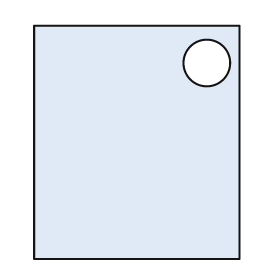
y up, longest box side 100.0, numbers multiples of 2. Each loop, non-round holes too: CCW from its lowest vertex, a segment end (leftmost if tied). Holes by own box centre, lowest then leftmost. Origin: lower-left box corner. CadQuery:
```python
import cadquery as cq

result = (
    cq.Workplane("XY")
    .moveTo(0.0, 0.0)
    .lineTo(88.0, 0.0)
    .lineTo(88.0, 100.0)
    .lineTo(0.0, 100.0)
    .close()
    .moveTo(74.0, 84.0)
    .circle(10.0)
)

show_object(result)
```